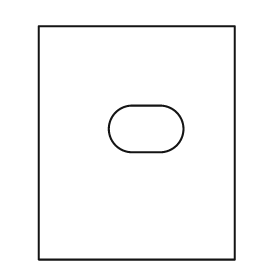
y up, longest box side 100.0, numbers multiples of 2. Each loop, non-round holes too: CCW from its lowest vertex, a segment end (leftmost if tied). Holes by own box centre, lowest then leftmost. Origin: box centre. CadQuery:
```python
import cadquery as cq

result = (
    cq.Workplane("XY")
    .moveTo(-42.0, -50.0)
    .lineTo(42.0, -50.0)
    .lineTo(42.0, 50.0)
    .lineTo(-42.0, 50.0)
    .close()
    .moveTo(-2.0, -4.0)
    .lineTo(10.0, -4.0)
    .threePointArc((20.0, 6.0), (10.0, 16.0))
    .lineTo(-2.0, 16.0)
    .threePointArc((-12.0, 6.0), (-2.0, -4.0))
    .close()
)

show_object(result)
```